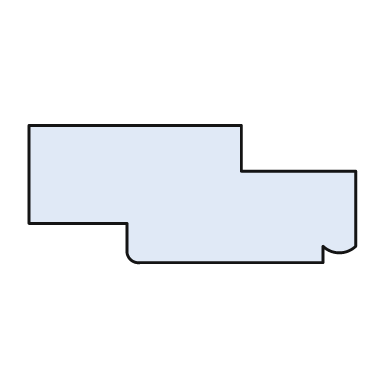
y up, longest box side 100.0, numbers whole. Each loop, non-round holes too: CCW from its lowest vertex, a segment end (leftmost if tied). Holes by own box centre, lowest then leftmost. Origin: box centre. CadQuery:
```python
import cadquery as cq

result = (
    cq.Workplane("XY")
    .moveTo(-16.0, -21.0)
    .lineTo(40.0, -21.0)
    .lineTo(40.0, -16.0)
    .threePointArc((45.0, -18.0), (50.0, -16.0))
    .lineTo(50.0, 7.0)
    .lineTo(15.0, 7.0)
    .lineTo(15.0, 21.0)
    .lineTo(-50.0, 21.0)
    .lineTo(-50.0, -9.0)
    .lineTo(-20.0, -9.0)
    .lineTo(-20.0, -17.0)
    .threePointArc((-19.0, -20.0), (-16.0, -21.0))
    .close()
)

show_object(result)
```